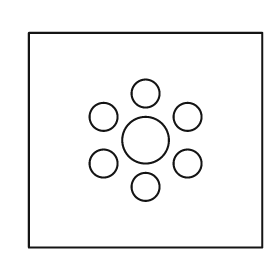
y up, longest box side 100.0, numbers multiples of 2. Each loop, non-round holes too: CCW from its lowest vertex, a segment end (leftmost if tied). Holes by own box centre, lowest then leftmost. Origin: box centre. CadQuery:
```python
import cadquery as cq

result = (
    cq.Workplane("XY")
    .moveTo(-50.0, -46.0)
    .lineTo(50.0, -46.0)
    .lineTo(50.0, 46.0)
    .lineTo(-50.0, 46.0)
    .close()
    .moveTo(0.0, -20.0)
    .circle(6.0)
    .moveTo(-18.0, -10.0)
    .circle(6.0)
    .moveTo(18.0, -10.0)
    .circle(6.0)
    .moveTo(0.0, 0.0)
    .circle(10.0)
    .moveTo(-18.0, 10.0)
    .circle(6.0)
    .moveTo(18.0, 10.0)
    .circle(6.0)
    .moveTo(0.0, 20.0)
    .circle(6.0)
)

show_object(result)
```